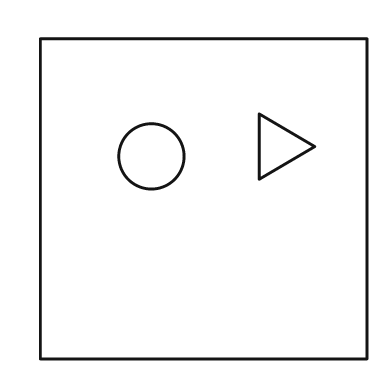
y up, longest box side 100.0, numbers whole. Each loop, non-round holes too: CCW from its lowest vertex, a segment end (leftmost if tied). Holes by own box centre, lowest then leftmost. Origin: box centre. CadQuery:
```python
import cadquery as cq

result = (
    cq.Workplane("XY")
    .moveTo(-50.0, -49.0)
    .lineTo(50.0, -49.0)
    .lineTo(50.0, 49.0)
    .lineTo(-50.0, 49.0)
    .close()
    .moveTo(-16.0, 13.0)
    .circle(10.0)
    .moveTo(17.0, 6.0)
    .lineTo(34.0, 16.0)
    .lineTo(17.0, 26.0)
    .close()
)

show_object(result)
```